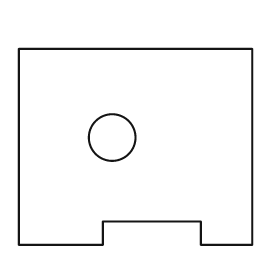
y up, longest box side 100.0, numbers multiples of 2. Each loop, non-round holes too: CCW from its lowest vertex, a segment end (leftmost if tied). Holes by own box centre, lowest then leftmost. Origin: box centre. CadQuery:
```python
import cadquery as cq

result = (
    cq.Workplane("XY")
    .moveTo(-50.0, -42.0)
    .lineTo(-14.0, -42.0)
    .lineTo(-14.0, -32.0)
    .lineTo(28.0, -32.0)
    .lineTo(28.0, -42.0)
    .lineTo(50.0, -42.0)
    .lineTo(50.0, 42.0)
    .lineTo(-50.0, 42.0)
    .close()
    .moveTo(-10.0, 4.0)
    .circle(10.0)
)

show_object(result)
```